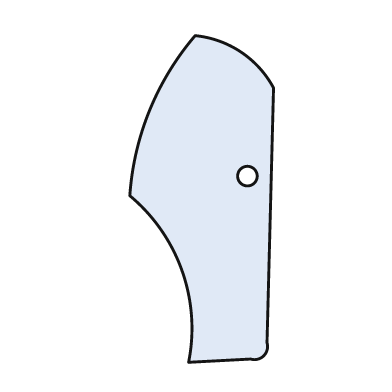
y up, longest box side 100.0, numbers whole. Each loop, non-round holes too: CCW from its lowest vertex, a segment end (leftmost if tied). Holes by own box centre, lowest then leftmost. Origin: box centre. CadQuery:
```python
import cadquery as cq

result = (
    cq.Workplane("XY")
    .moveTo(-4.0, -50.0)
    .lineTo(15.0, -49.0)
    .threePointArc((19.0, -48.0), (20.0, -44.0))
    .lineTo(22.0, 34.0)
    .threePointArc((12.0, 45.0), (-2.0, 50.0))
    .threePointArc((-16.0, 27.0), (-22.0, 1.0))
    .threePointArc((-6.0, -22.0), (-4.0, -50.0))
    .close()
    .moveTo(14.0, 7.0)
    .circle(3.0)
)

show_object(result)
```